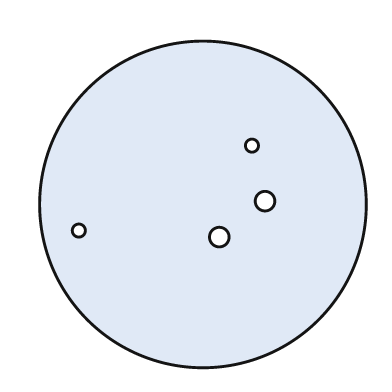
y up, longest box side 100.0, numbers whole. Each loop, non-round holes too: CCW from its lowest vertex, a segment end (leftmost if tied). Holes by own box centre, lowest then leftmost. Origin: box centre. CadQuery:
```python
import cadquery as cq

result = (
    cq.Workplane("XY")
    .moveTo(0.0, 0.0)
    .circle(50.0)
    .moveTo(5.0, -10.0)
    .circle(3.0)
    .moveTo(-38.0, -8.0)
    .circle(2.0)
    .moveTo(19.0, 1.0)
    .circle(3.0)
    .moveTo(15.0, 18.0)
    .circle(2.0)
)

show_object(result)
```